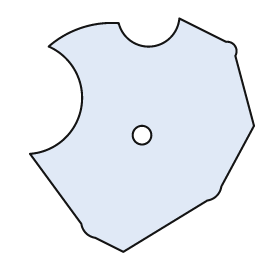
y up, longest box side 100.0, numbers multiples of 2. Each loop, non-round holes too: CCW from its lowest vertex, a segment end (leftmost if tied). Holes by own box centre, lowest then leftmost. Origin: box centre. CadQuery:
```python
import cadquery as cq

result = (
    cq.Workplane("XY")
    .moveTo(-8.0, -50.0)
    .lineTo(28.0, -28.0)
    .threePointArc((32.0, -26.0), (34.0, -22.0))
    .lineTo(48.0, 4.0)
    .lineTo(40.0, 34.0)
    .threePointArc((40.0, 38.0), (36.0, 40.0))
    .lineTo(16.0, 50.0)
    .threePointArc((4.0, 38.0), (-10.0, 48.0))
    .threePointArc((-26.0, 46.0), (-40.0, 38.0))
    .threePointArc((-26.0, 12.0), (-48.0, -8.0))
    .lineTo(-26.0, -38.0)
    .threePointArc((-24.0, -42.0), (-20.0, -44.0))
    .close()
    .moveTo(0.0, 0.0)
    .circle(4.0)
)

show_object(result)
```